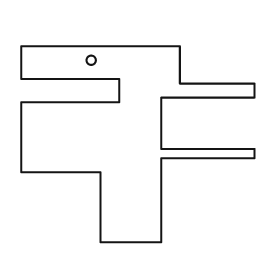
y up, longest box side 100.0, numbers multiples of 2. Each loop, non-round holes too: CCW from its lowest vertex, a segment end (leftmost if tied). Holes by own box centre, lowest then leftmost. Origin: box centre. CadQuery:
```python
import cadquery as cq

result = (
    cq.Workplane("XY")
    .moveTo(-16.0, -42.0)
    .lineTo(10.0, -42.0)
    .lineTo(10.0, -6.0)
    .lineTo(50.0, -6.0)
    .lineTo(50.0, -2.0)
    .lineTo(10.0, -2.0)
    .lineTo(10.0, 20.0)
    .lineTo(50.0, 20.0)
    .lineTo(50.0, 26.0)
    .lineTo(18.0, 26.0)
    .lineTo(18.0, 42.0)
    .lineTo(-50.0, 42.0)
    .lineTo(-50.0, 28.0)
    .lineTo(-8.0, 28.0)
    .lineTo(-8.0, 18.0)
    .lineTo(-50.0, 18.0)
    .lineTo(-50.0, -12.0)
    .lineTo(-16.0, -12.0)
    .close()
    .moveTo(-20.0, 36.0)
    .circle(2.0)
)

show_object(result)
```